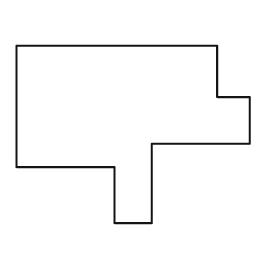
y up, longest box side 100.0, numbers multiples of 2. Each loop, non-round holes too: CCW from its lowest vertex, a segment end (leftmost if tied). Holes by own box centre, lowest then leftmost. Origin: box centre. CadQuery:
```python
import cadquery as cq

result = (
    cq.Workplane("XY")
    .moveTo(-8.0, -38.0)
    .lineTo(8.0, -38.0)
    .lineTo(8.0, -4.0)
    .lineTo(50.0, -4.0)
    .lineTo(50.0, 16.0)
    .lineTo(36.0, 16.0)
    .lineTo(36.0, 38.0)
    .lineTo(-50.0, 38.0)
    .lineTo(-50.0, -14.0)
    .lineTo(-8.0, -14.0)
    .close()
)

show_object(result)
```